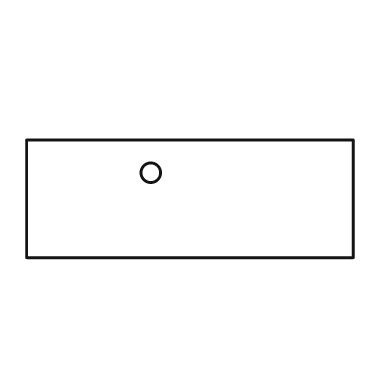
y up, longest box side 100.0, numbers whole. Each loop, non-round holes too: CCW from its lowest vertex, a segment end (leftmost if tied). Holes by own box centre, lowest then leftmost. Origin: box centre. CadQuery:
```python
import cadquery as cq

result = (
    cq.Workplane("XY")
    .moveTo(-50.0, -18.0)
    .lineTo(50.0, -18.0)
    .lineTo(50.0, 18.0)
    .lineTo(-50.0, 18.0)
    .close()
    .moveTo(-12.0, 8.0)
    .circle(3.0)
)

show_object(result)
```